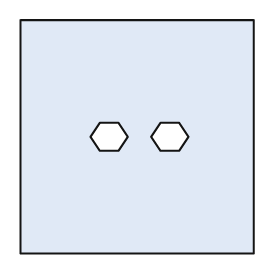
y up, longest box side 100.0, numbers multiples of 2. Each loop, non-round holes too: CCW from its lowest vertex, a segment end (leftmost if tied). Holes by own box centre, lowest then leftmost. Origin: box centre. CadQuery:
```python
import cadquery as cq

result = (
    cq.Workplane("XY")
    .moveTo(-50.0, -50.0)
    .lineTo(50.0, -50.0)
    .lineTo(50.0, 50.0)
    .lineTo(-50.0, 50.0)
    .close()
    .moveTo(-16.0, -6.0)
    .lineTo(-8.0, -6.0)
    .lineTo(-4.0, 0.0)
    .lineTo(-8.0, 6.0)
    .lineTo(-16.0, 6.0)
    .lineTo(-20.0, 0.0)
    .close()
    .moveTo(10.0, -6.0)
    .lineTo(18.0, -6.0)
    .lineTo(22.0, 0.0)
    .lineTo(18.0, 6.0)
    .lineTo(10.0, 6.0)
    .lineTo(6.0, 0.0)
    .close()
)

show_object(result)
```